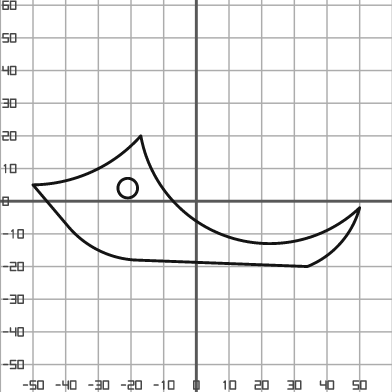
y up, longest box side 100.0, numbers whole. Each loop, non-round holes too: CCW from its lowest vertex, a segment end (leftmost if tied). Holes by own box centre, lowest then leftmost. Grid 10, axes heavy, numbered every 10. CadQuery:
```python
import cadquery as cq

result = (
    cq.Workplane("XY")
    .moveTo(34.0, -20.0)
    .threePointArc((44.0, -13.0), (50.0, -2.0))
    .threePointArc((10.0, -11.0), (-17.0, 20.0))
    .threePointArc((-32.0, 9.0), (-50.0, 5.0))
    .lineTo(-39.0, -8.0)
    .threePointArc((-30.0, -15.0), (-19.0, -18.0))
    .close()
    .moveTo(-21.0, 4.0)
    .circle(3.0)
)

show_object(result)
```